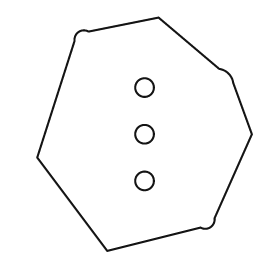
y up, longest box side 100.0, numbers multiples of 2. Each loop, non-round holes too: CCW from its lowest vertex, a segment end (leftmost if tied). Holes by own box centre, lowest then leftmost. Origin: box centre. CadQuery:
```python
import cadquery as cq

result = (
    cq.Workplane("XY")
    .moveTo(-16.0, -50.0)
    .lineTo(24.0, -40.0)
    .threePointArc((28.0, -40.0), (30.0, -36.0))
    .lineTo(46.0, 0.0)
    .lineTo(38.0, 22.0)
    .threePointArc((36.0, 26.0), (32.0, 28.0))
    .lineTo(6.0, 50.0)
    .lineTo(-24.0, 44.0)
    .threePointArc((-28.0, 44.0), (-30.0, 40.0))
    .lineTo(-46.0, -10.0)
    .close()
    .moveTo(0.0, -20.0)
    .circle(4.0)
    .moveTo(0.0, 0.0)
    .circle(4.0)
    .moveTo(0.0, 20.0)
    .circle(4.0)
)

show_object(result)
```